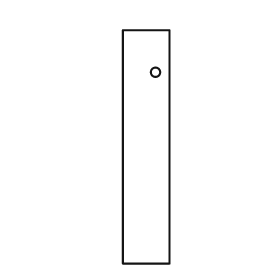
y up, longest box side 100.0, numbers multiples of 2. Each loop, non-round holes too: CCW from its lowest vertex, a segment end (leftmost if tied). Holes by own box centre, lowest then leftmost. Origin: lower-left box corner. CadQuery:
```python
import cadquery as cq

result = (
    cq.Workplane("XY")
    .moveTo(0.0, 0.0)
    .lineTo(20.0, 0.0)
    .lineTo(20.0, 100.0)
    .lineTo(0.0, 100.0)
    .close()
    .moveTo(14.0, 82.0)
    .circle(2.0)
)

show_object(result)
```